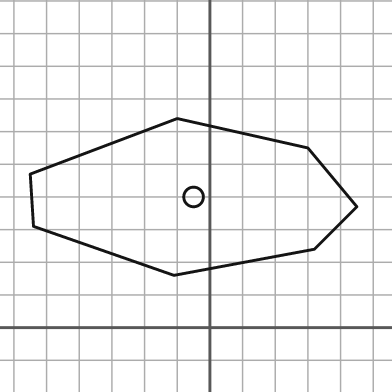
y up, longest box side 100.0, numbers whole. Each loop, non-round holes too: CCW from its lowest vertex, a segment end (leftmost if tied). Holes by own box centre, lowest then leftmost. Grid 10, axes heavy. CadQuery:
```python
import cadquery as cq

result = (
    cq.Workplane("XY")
    .moveTo(-11.0, 16.0)
    .lineTo(32.0, 24.0)
    .lineTo(45.0, 37.0)
    .lineTo(30.0, 55.0)
    .lineTo(-10.0, 64.0)
    .lineTo(-55.0, 47.0)
    .lineTo(-54.0, 31.0)
    .close()
    .moveTo(-5.0, 40.0)
    .circle(3.0)
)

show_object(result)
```